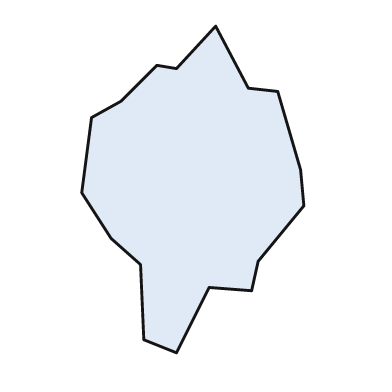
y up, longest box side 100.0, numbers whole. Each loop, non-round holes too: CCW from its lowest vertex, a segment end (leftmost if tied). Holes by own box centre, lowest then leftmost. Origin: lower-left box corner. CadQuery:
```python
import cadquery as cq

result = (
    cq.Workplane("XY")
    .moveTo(29.0, 0.0)
    .lineTo(39.0, 20.0)
    .lineTo(52.0, 19.0)
    .lineTo(54.0, 28.0)
    .lineTo(68.0, 45.0)
    .lineTo(67.0, 56.0)
    .lineTo(60.0, 80.0)
    .lineTo(51.0, 81.0)
    .lineTo(41.0, 100.0)
    .lineTo(29.0, 87.0)
    .lineTo(23.0, 88.0)
    .lineTo(12.0, 77.0)
    .lineTo(3.0, 72.0)
    .lineTo(0.0, 49.0)
    .lineTo(9.0, 35.0)
    .lineTo(18.0, 27.0)
    .lineTo(19.0, 4.0)
    .close()
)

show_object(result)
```